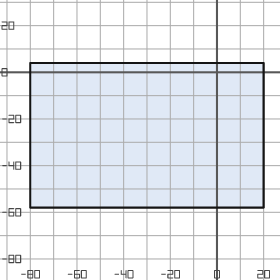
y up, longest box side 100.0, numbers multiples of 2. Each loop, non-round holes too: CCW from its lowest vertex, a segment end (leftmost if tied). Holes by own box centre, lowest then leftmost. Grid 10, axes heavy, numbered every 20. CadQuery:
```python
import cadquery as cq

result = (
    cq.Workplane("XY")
    .moveTo(-80.0, -58.0)
    .lineTo(20.0, -58.0)
    .lineTo(20.0, 4.0)
    .lineTo(-80.0, 4.0)
    .close()
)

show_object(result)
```